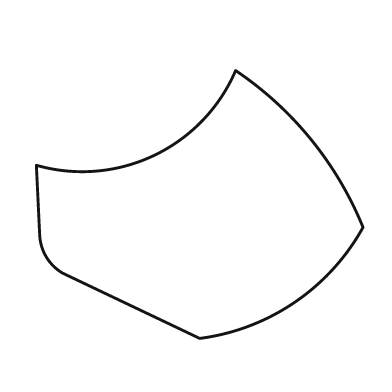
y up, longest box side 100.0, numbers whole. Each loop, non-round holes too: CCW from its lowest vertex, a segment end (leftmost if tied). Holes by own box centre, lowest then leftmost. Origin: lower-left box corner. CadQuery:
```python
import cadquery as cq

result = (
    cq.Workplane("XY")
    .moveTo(50.0, 0.0)
    .threePointArc((79.0, 11.0), (100.0, 34.0))
    .threePointArc((84.0, 61.0), (61.0, 82.0))
    .threePointArc((36.0, 56.0), (0.0, 53.0))
    .lineTo(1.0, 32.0)
    .threePointArc((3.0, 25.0), (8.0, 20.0))
    .close()
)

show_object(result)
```